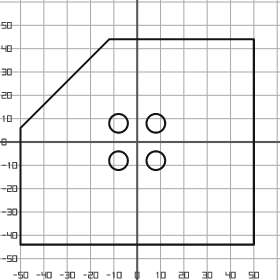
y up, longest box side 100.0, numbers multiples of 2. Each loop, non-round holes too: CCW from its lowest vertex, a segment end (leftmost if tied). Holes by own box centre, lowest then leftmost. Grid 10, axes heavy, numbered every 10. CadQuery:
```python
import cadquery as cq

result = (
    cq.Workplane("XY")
    .moveTo(-50.0, -44.0)
    .lineTo(50.0, -44.0)
    .lineTo(50.0, 44.0)
    .lineTo(-12.0, 44.0)
    .lineTo(-50.0, 6.0)
    .close()
    .moveTo(-8.0, -8.0)
    .circle(4.0)
    .moveTo(8.0, -8.0)
    .circle(4.0)
    .moveTo(-8.0, 8.0)
    .circle(4.0)
    .moveTo(8.0, 8.0)
    .circle(4.0)
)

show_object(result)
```